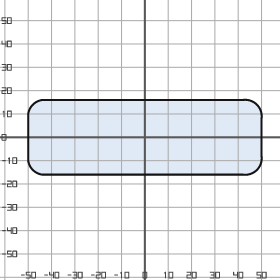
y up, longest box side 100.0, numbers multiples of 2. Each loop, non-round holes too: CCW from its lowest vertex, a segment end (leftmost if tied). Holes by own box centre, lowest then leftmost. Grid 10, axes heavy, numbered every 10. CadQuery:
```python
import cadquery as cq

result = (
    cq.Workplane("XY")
    .moveTo(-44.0, -16.0)
    .lineTo(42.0, -16.0)
    .threePointArc((48.0, -14.0), (50.0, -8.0))
    .lineTo(50.0, 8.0)
    .threePointArc((48.0, 14.0), (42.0, 16.0))
    .lineTo(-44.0, 16.0)
    .threePointArc((-48.0, 14.0), (-50.0, 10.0))
    .lineTo(-50.0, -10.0)
    .threePointArc((-48.0, -14.0), (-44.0, -16.0))
    .close()
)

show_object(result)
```